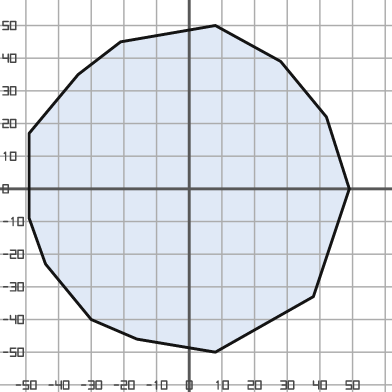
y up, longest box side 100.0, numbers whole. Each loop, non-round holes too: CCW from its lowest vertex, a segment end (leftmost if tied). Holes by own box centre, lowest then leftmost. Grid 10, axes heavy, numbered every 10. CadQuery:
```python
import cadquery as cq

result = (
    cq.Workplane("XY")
    .moveTo(8.0, -50.0)
    .lineTo(38.0, -33.0)
    .lineTo(49.0, 0.0)
    .lineTo(42.0, 22.0)
    .lineTo(28.0, 39.0)
    .lineTo(8.0, 50.0)
    .lineTo(-21.0, 45.0)
    .lineTo(-34.0, 35.0)
    .lineTo(-49.0, 17.0)
    .lineTo(-49.0, -9.0)
    .lineTo(-44.0, -23.0)
    .lineTo(-30.0, -40.0)
    .lineTo(-16.0, -46.0)
    .close()
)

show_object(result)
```